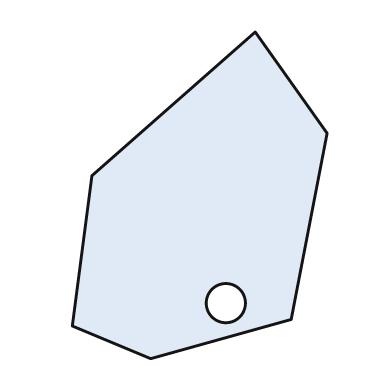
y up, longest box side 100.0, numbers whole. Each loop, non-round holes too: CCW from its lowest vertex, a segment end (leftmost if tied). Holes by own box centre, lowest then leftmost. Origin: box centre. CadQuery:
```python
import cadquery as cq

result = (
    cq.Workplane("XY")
    .moveTo(-15.0, -50.0)
    .lineTo(28.0, -38.0)
    .lineTo(39.0, 19.0)
    .lineTo(17.0, 50.0)
    .lineTo(-33.0, 6.0)
    .lineTo(-39.0, -40.0)
    .close()
    .moveTo(8.0, -33.0)
    .circle(6.0)
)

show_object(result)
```